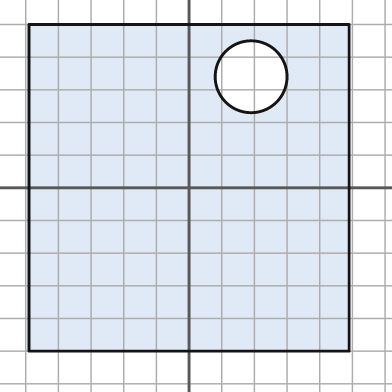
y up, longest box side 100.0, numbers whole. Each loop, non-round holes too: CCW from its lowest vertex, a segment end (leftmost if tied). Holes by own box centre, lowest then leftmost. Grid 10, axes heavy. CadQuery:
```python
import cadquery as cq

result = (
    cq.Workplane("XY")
    .moveTo(-49.0, -50.0)
    .lineTo(49.0, -50.0)
    .lineTo(49.0, 50.0)
    .lineTo(-49.0, 50.0)
    .close()
    .moveTo(19.0, 34.0)
    .circle(11.0)
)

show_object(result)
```